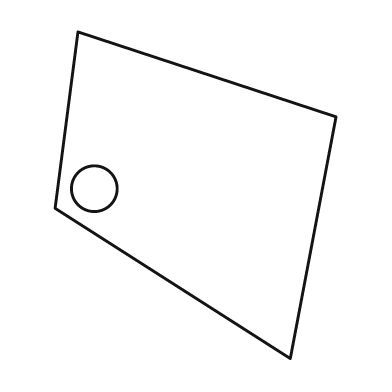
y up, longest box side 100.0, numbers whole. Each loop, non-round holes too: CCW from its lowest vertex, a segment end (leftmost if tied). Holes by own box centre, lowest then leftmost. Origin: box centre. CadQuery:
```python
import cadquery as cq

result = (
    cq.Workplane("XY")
    .moveTo(29.0, -50.0)
    .lineTo(43.0, 24.0)
    .lineTo(-36.0, 50.0)
    .lineTo(-43.0, -4.0)
    .close()
    .moveTo(-31.0, 2.0)
    .circle(7.0)
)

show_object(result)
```